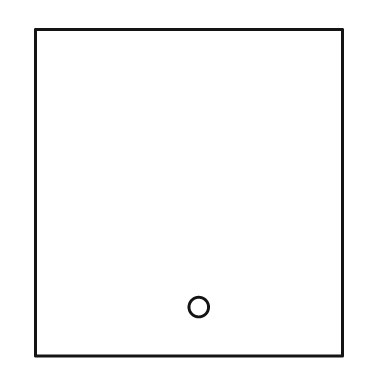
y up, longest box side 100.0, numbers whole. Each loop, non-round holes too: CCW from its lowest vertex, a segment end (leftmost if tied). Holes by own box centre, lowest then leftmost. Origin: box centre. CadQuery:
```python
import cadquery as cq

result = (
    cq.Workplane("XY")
    .moveTo(-47.0, -50.0)
    .lineTo(47.0, -50.0)
    .lineTo(47.0, 50.0)
    .lineTo(-47.0, 50.0)
    .close()
    .moveTo(3.0, -35.0)
    .circle(3.0)
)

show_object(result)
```